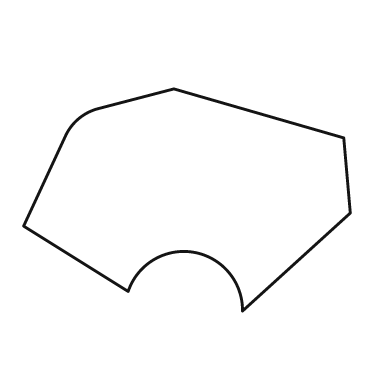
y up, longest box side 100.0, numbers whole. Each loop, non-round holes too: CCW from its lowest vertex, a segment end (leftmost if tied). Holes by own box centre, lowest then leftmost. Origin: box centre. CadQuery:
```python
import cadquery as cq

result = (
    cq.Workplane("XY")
    .moveTo(17.0, -34.0)
    .lineTo(50.0, -4.0)
    .lineTo(48.0, 19.0)
    .lineTo(-4.0, 34.0)
    .lineTo(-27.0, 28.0)
    .threePointArc((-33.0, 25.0), (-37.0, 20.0))
    .lineTo(-50.0, -8.0)
    .lineTo(-18.0, -28.0)
    .threePointArc((2.0, -16.0), (17.0, -34.0))
    .close()
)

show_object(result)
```